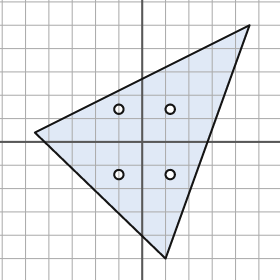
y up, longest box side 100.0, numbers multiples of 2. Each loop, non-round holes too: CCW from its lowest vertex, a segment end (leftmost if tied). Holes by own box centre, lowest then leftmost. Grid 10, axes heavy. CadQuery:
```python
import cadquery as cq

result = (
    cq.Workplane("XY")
    .moveTo(10.0, -50.0)
    .lineTo(46.0, 50.0)
    .lineTo(-46.0, 4.0)
    .close()
    .moveTo(-10.0, -14.0)
    .circle(2.0)
    .moveTo(12.0, -14.0)
    .circle(2.0)
    .moveTo(-10.0, 14.0)
    .circle(2.0)
    .moveTo(12.0, 14.0)
    .circle(2.0)
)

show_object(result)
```